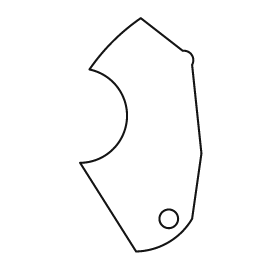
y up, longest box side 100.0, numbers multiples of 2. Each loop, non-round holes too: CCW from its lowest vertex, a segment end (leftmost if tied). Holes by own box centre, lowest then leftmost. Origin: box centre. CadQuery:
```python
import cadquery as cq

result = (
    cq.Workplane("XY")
    .moveTo(-2.0, -50.0)
    .threePointArc((12.0, -46.0), (22.0, -36.0))
    .lineTo(26.0, -8.0)
    .lineTo(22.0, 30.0)
    .threePointArc((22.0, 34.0), (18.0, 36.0))
    .lineTo(0.0, 50.0)
    .threePointArc((-12.0, 40.0), (-22.0, 28.0))
    .threePointArc((-6.0, 6.0), (-26.0, -12.0))
    .close()
    .moveTo(12.0, -36.0)
    .circle(4.0)
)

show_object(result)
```